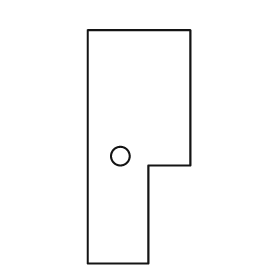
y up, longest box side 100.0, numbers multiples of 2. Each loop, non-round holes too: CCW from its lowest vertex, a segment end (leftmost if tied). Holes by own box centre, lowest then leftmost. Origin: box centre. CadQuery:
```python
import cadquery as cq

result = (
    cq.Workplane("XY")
    .moveTo(-22.0, -50.0)
    .lineTo(4.0, -50.0)
    .lineTo(4.0, -8.0)
    .lineTo(22.0, -8.0)
    .lineTo(22.0, 50.0)
    .lineTo(-22.0, 50.0)
    .close()
    .moveTo(-8.0, -4.0)
    .circle(4.0)
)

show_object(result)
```